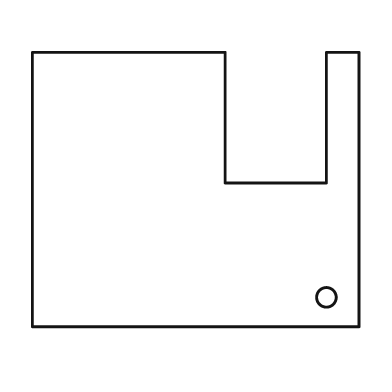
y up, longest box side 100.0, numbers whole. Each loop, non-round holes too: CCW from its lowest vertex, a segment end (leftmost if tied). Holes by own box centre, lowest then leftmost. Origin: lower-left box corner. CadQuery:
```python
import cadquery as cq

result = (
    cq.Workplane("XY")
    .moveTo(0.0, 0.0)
    .lineTo(100.0, 0.0)
    .lineTo(100.0, 84.0)
    .lineTo(90.0, 84.0)
    .lineTo(90.0, 44.0)
    .lineTo(59.0, 44.0)
    .lineTo(59.0, 84.0)
    .lineTo(0.0, 84.0)
    .close()
    .moveTo(90.0, 9.0)
    .circle(3.0)
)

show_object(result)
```